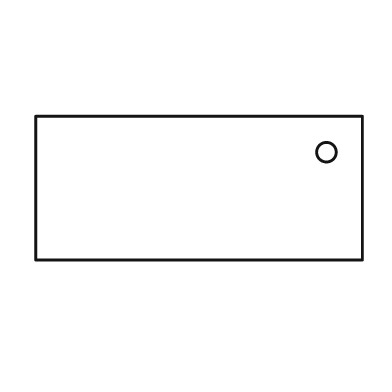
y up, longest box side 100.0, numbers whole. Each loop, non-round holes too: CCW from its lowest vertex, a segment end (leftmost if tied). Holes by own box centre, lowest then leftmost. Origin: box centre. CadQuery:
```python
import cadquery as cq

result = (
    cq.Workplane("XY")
    .moveTo(-50.0, -22.0)
    .lineTo(50.0, -22.0)
    .lineTo(50.0, 22.0)
    .lineTo(-50.0, 22.0)
    .close()
    .moveTo(39.0, 11.0)
    .circle(3.0)
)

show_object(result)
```